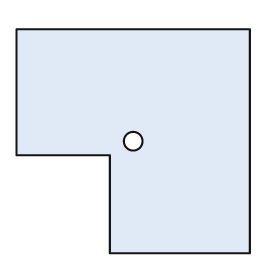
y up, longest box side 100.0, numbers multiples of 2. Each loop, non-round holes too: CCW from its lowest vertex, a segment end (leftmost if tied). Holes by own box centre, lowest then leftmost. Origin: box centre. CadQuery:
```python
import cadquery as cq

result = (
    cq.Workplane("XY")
    .moveTo(-10.0, -48.0)
    .lineTo(50.0, -48.0)
    .lineTo(50.0, 48.0)
    .lineTo(-50.0, 48.0)
    .lineTo(-50.0, -6.0)
    .lineTo(-10.0, -6.0)
    .close()
    .moveTo(0.0, 0.0)
    .circle(4.0)
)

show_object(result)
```